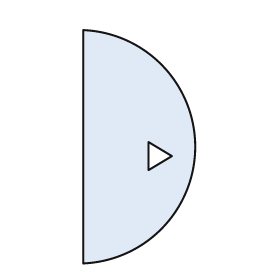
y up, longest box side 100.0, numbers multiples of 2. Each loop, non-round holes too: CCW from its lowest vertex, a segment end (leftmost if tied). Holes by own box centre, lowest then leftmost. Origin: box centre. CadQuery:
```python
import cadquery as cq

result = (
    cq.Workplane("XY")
    .moveTo(-24.0, -50.0)
    .threePointArc((24.0, 0.0), (-24.0, 50.0))
    .close()
    .moveTo(4.0, -10.0)
    .lineTo(14.0, -4.0)
    .lineTo(4.0, 2.0)
    .close()
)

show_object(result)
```